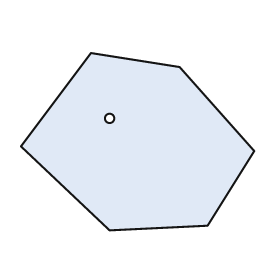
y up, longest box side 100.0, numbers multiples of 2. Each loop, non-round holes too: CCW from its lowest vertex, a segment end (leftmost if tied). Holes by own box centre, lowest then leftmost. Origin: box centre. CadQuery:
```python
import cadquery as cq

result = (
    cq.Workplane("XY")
    .moveTo(-12.0, -38.0)
    .lineTo(30.0, -36.0)
    .lineTo(50.0, -4.0)
    .lineTo(18.0, 32.0)
    .lineTo(-20.0, 38.0)
    .lineTo(-50.0, -2.0)
    .close()
    .moveTo(-12.0, 10.0)
    .circle(2.0)
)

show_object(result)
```